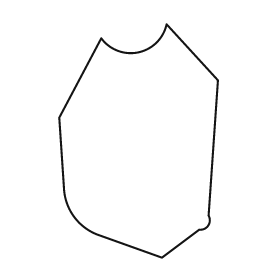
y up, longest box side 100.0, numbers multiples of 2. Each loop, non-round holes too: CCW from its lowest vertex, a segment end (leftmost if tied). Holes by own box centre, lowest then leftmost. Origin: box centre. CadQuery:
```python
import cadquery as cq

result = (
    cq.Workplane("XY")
    .moveTo(10.0, -50.0)
    .lineTo(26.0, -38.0)
    .threePointArc((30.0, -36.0), (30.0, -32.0))
    .lineTo(34.0, 26.0)
    .lineTo(12.0, 50.0)
    .threePointArc((0.0, 38.0), (-16.0, 44.0))
    .lineTo(-34.0, 10.0)
    .lineTo(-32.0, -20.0)
    .threePointArc((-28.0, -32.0), (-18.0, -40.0))
    .close()
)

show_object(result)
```